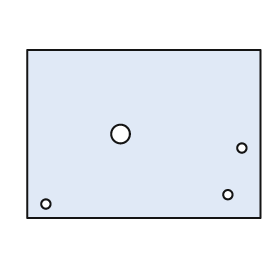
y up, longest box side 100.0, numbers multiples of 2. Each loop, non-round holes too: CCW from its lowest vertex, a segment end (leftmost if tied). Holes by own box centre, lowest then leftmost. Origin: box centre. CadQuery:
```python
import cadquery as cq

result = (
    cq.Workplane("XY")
    .moveTo(-50.0, -36.0)
    .lineTo(50.0, -36.0)
    .lineTo(50.0, 36.0)
    .lineTo(-50.0, 36.0)
    .close()
    .moveTo(-42.0, -30.0)
    .circle(2.0)
    .moveTo(36.0, -26.0)
    .circle(2.0)
    .moveTo(42.0, -6.0)
    .circle(2.0)
    .moveTo(-10.0, 0.0)
    .circle(4.0)
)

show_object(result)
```